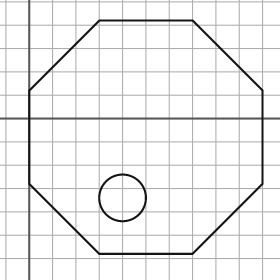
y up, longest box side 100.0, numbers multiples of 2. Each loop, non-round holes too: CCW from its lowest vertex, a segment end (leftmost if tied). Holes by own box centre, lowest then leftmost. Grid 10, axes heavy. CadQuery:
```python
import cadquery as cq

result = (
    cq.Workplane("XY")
    .moveTo(30.0, -58.0)
    .lineTo(70.0, -58.0)
    .lineTo(100.0, -28.0)
    .lineTo(100.0, 12.0)
    .lineTo(70.0, 42.0)
    .lineTo(30.0, 42.0)
    .lineTo(0.0, 12.0)
    .lineTo(0.0, -28.0)
    .close()
    .moveTo(40.0, -34.0)
    .circle(10.0)
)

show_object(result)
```